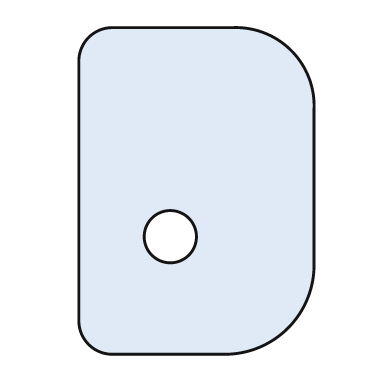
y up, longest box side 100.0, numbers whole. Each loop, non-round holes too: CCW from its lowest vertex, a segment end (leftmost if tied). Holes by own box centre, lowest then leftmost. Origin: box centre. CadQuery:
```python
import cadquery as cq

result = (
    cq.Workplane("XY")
    .moveTo(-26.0, -50.0)
    .lineTo(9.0, -50.0)
    .threePointArc((28.0, -42.0), (36.0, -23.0))
    .lineTo(36.0, 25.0)
    .threePointArc((29.0, 43.0), (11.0, 50.0))
    .lineTo(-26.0, 50.0)
    .threePointArc((-33.0, 47.0), (-36.0, 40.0))
    .lineTo(-36.0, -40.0)
    .threePointArc((-33.0, -47.0), (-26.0, -50.0))
    .close()
    .moveTo(-8.0, -14.0)
    .circle(8.0)
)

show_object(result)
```